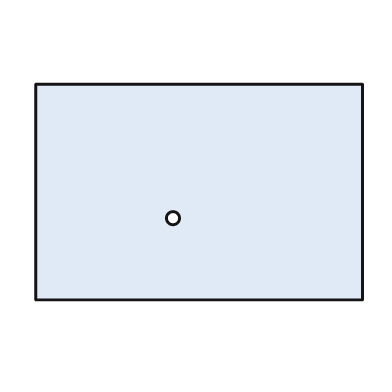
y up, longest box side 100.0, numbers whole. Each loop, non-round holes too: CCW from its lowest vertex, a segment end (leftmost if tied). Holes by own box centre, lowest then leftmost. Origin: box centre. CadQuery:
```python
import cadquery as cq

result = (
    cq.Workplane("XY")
    .moveTo(-50.0, -33.0)
    .lineTo(50.0, -33.0)
    .lineTo(50.0, 33.0)
    .lineTo(-50.0, 33.0)
    .close()
    .moveTo(-8.0, -8.0)
    .circle(2.0)
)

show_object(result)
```